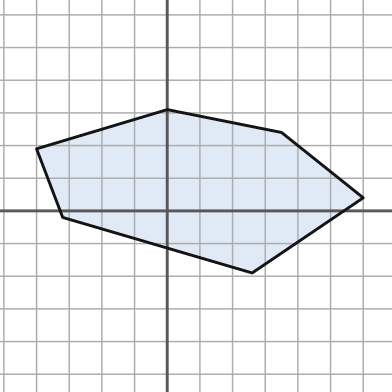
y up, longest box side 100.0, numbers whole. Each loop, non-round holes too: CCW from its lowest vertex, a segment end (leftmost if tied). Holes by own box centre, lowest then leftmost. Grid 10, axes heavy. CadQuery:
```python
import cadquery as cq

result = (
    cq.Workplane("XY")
    .moveTo(26.0, -19.0)
    .lineTo(60.0, 4.0)
    .lineTo(35.0, 24.0)
    .lineTo(0.0, 31.0)
    .lineTo(-40.0, 19.0)
    .lineTo(-32.0, -2.0)
    .close()
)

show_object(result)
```